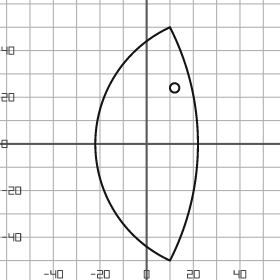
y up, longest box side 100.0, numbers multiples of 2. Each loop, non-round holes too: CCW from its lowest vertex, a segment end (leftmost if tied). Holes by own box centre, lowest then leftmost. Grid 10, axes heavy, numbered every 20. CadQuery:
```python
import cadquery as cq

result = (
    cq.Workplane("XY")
    .moveTo(10.0, -50.0)
    .threePointArc((22.0, 0.0), (10.0, 50.0))
    .threePointArc((-22.0, 0.0), (10.0, -50.0))
    .close()
    .moveTo(12.0, 24.0)
    .circle(2.0)
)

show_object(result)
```